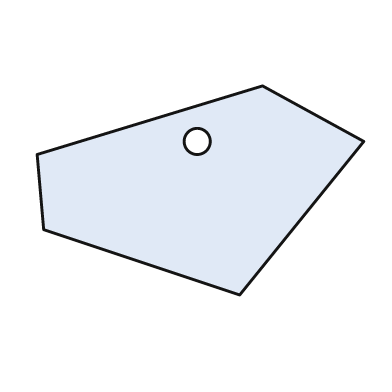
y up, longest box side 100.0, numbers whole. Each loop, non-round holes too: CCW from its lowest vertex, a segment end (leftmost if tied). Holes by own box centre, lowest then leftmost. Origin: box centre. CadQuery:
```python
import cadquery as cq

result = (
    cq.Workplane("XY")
    .moveTo(12.0, -32.0)
    .lineTo(50.0, 15.0)
    .lineTo(19.0, 32.0)
    .lineTo(-50.0, 11.0)
    .lineTo(-48.0, -12.0)
    .close()
    .moveTo(-1.0, 15.0)
    .circle(4.0)
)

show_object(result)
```